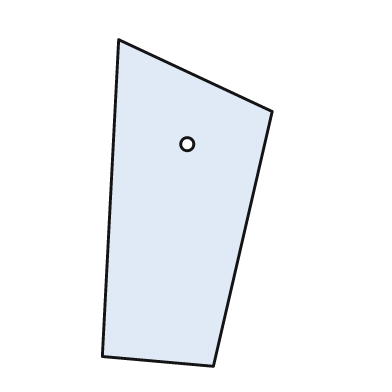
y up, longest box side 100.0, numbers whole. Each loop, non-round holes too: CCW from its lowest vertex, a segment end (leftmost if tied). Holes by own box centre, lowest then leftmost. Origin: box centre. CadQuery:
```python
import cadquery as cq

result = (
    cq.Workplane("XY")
    .moveTo(8.0, -50.0)
    .lineTo(26.0, 28.0)
    .lineTo(-21.0, 50.0)
    .lineTo(-26.0, -47.0)
    .close()
    .moveTo(0.0, 18.0)
    .circle(2.0)
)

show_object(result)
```